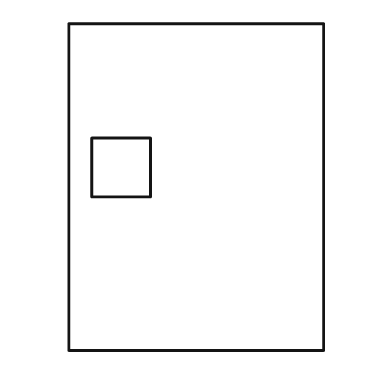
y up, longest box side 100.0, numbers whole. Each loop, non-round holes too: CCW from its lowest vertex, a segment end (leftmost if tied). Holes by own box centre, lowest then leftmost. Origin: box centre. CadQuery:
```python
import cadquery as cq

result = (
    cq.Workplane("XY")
    .moveTo(-39.0, -50.0)
    .lineTo(39.0, -50.0)
    .lineTo(39.0, 50.0)
    .lineTo(-39.0, 50.0)
    .close()
    .moveTo(-32.0, -3.0)
    .lineTo(-14.0, -3.0)
    .lineTo(-14.0, 15.0)
    .lineTo(-32.0, 15.0)
    .close()
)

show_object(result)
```